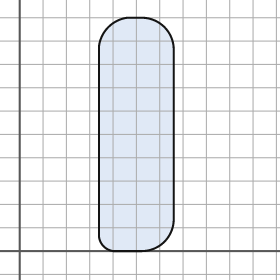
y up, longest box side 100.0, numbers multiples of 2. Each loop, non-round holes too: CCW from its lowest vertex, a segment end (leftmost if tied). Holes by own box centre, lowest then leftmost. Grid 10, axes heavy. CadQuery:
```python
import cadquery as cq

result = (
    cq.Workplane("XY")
    .moveTo(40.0, 0.0)
    .lineTo(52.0, 0.0)
    .threePointArc((62.0, 4.0), (66.0, 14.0))
    .lineTo(66.0, 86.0)
    .threePointArc((62.0, 96.0), (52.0, 100.0))
    .lineTo(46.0, 100.0)
    .threePointArc((38.0, 96.0), (34.0, 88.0))
    .lineTo(34.0, 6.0)
    .threePointArc((36.0, 2.0), (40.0, 0.0))
    .close()
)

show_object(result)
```